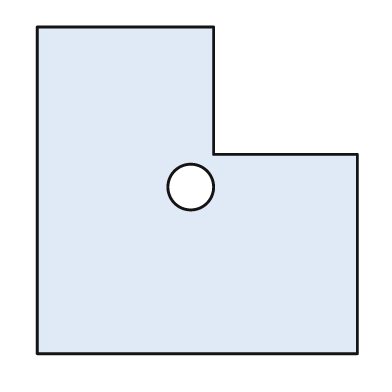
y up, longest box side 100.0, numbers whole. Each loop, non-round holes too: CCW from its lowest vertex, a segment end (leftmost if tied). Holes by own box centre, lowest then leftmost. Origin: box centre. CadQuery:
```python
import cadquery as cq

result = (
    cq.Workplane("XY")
    .moveTo(-49.0, -50.0)
    .lineTo(49.0, -50.0)
    .lineTo(49.0, 11.0)
    .lineTo(5.0, 11.0)
    .lineTo(5.0, 50.0)
    .lineTo(-49.0, 50.0)
    .close()
    .moveTo(-2.0, 1.0)
    .circle(7.0)
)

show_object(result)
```